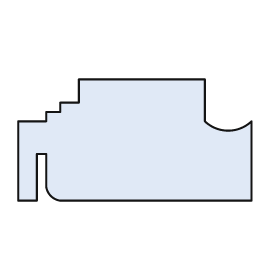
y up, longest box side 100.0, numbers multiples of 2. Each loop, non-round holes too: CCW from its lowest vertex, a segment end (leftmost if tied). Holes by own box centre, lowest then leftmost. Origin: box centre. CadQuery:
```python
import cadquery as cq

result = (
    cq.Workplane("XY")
    .moveTo(-50.0, -26.0)
    .lineTo(-42.0, -26.0)
    .lineTo(-42.0, -6.0)
    .lineTo(-38.0, -6.0)
    .lineTo(-38.0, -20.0)
    .threePointArc((-36.0, -24.0), (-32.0, -26.0))
    .lineTo(50.0, -26.0)
    .lineTo(50.0, 8.0)
    .threePointArc((40.0, 4.0), (30.0, 8.0))
    .lineTo(30.0, 26.0)
    .lineTo(-24.0, 26.0)
    .lineTo(-24.0, 16.0)
    .lineTo(-32.0, 16.0)
    .lineTo(-32.0, 12.0)
    .lineTo(-38.0, 12.0)
    .lineTo(-38.0, 8.0)
    .lineTo(-50.0, 8.0)
    .close()
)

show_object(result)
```